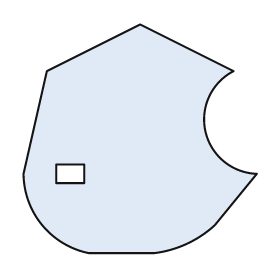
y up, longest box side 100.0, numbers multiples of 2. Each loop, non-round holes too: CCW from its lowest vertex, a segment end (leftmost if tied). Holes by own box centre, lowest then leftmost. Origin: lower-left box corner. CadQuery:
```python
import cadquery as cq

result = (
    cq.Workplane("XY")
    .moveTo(28.0, 0.0)
    .lineTo(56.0, 0.0)
    .threePointArc((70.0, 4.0), (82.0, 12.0))
    .lineTo(100.0, 34.0)
    .threePointArc((78.0, 52.0), (90.0, 78.0))
    .lineTo(50.0, 98.0)
    .lineTo(10.0, 78.0)
    .lineTo(0.0, 34.0)
    .threePointArc((8.0, 12.0), (28.0, 0.0))
    .close()
    .moveTo(14.0, 30.0)
    .lineTo(26.0, 30.0)
    .lineTo(26.0, 38.0)
    .lineTo(14.0, 38.0)
    .close()
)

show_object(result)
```